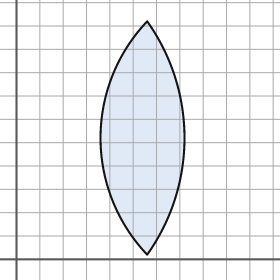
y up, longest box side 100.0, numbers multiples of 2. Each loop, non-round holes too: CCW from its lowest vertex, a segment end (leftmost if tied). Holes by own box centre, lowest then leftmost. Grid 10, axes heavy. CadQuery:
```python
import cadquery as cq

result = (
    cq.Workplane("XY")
    .moveTo(56.0, 2.0)
    .threePointArc((72.0, 52.0), (56.0, 102.0))
    .threePointArc((36.0, 52.0), (56.0, 2.0))
    .close()
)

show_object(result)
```